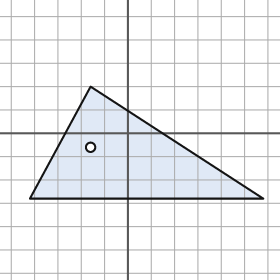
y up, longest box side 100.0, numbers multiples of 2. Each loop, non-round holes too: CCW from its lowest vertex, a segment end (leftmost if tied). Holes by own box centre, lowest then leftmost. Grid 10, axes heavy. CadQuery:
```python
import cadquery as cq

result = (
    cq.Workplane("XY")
    .moveTo(-42.0, -28.0)
    .lineTo(58.0, -28.0)
    .lineTo(-16.0, 20.0)
    .close()
    .moveTo(-16.0, -6.0)
    .circle(2.0)
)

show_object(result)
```